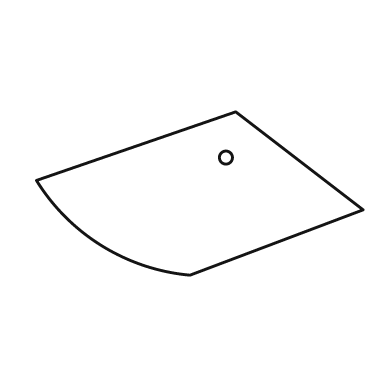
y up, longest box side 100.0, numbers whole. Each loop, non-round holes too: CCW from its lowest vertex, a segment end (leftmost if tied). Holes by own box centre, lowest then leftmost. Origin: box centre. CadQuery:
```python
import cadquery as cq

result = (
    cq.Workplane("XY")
    .moveTo(-3.0, -25.0)
    .lineTo(50.0, -5.0)
    .lineTo(11.0, 25.0)
    .lineTo(-50.0, 4.0)
    .threePointArc((-30.0, -16.0), (-3.0, -25.0))
    .close()
    .moveTo(8.0, 11.0)
    .circle(2.0)
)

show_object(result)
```